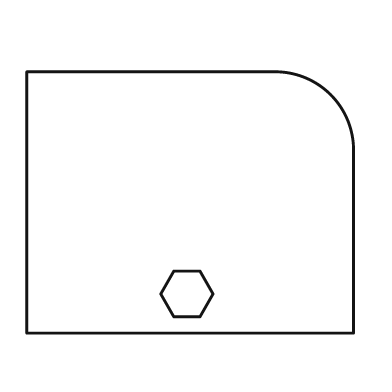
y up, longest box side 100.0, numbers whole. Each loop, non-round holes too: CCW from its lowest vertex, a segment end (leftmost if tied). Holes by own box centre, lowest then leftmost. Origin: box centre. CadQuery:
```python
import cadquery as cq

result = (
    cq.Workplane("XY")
    .moveTo(-50.0, -40.0)
    .lineTo(50.0, -40.0)
    .lineTo(50.0, 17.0)
    .threePointArc((43.0, 33.0), (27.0, 40.0))
    .lineTo(-50.0, 40.0)
    .close()
    .moveTo(-5.0, -35.0)
    .lineTo(3.0, -35.0)
    .lineTo(7.0, -28.0)
    .lineTo(3.0, -21.0)
    .lineTo(-5.0, -21.0)
    .lineTo(-9.0, -28.0)
    .close()
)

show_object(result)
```